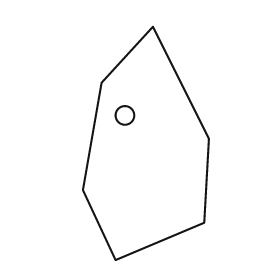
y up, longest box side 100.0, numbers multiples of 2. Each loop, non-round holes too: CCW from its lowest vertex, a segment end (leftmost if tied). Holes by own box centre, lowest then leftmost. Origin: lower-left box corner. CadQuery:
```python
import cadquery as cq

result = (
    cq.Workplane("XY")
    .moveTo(14.0, 0.0)
    .lineTo(52.0, 16.0)
    .lineTo(54.0, 52.0)
    .lineTo(30.0, 100.0)
    .lineTo(8.0, 76.0)
    .lineTo(0.0, 30.0)
    .close()
    .moveTo(18.0, 62.0)
    .circle(4.0)
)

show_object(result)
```